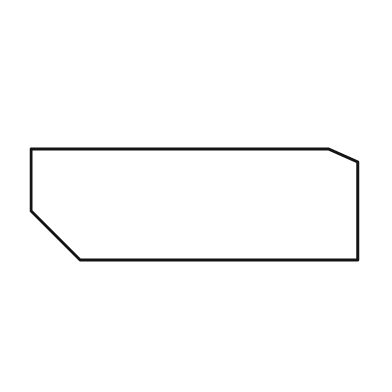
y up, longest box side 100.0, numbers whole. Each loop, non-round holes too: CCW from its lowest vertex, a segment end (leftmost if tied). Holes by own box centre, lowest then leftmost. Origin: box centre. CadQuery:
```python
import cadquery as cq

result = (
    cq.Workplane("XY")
    .moveTo(-35.0, -17.0)
    .lineTo(50.0, -17.0)
    .lineTo(50.0, 13.0)
    .lineTo(41.0, 17.0)
    .lineTo(-50.0, 17.0)
    .lineTo(-50.0, -2.0)
    .close()
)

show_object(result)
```